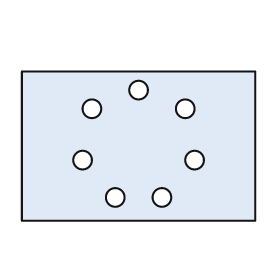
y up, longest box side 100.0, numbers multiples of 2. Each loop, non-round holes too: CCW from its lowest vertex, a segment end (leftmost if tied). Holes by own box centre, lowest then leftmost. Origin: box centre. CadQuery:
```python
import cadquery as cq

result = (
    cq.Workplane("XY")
    .moveTo(-50.0, -32.0)
    .lineTo(50.0, -32.0)
    .lineTo(50.0, 32.0)
    .lineTo(-50.0, 32.0)
    .close()
    .moveTo(-10.0, -22.0)
    .circle(4.0)
    .moveTo(10.0, -22.0)
    .circle(4.0)
    .moveTo(-24.0, -6.0)
    .circle(4.0)
    .moveTo(24.0, -6.0)
    .circle(4.0)
    .moveTo(-20.0, 16.0)
    .circle(4.0)
    .moveTo(20.0, 16.0)
    .circle(4.0)
    .moveTo(0.0, 24.0)
    .circle(4.0)
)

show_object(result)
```